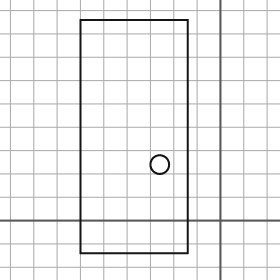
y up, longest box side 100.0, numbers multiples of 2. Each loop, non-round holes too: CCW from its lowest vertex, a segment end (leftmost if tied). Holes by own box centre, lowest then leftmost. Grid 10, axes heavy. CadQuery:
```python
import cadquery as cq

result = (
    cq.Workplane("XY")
    .moveTo(-60.0, -14.0)
    .lineTo(-14.0, -14.0)
    .lineTo(-14.0, 86.0)
    .lineTo(-60.0, 86.0)
    .close()
    .moveTo(-26.0, 24.0)
    .circle(4.0)
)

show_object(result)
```